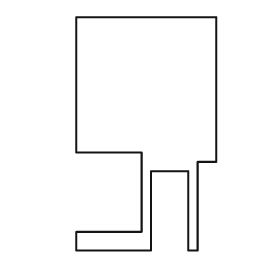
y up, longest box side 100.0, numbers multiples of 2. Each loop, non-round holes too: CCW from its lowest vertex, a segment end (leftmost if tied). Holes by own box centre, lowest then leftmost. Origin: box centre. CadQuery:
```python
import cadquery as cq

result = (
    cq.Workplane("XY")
    .moveTo(-30.0, -50.0)
    .lineTo(2.0, -50.0)
    .lineTo(2.0, -16.0)
    .lineTo(18.0, -16.0)
    .lineTo(18.0, -50.0)
    .lineTo(22.0, -50.0)
    .lineTo(22.0, -12.0)
    .lineTo(30.0, -12.0)
    .lineTo(30.0, 50.0)
    .lineTo(-30.0, 50.0)
    .lineTo(-30.0, -8.0)
    .lineTo(-2.0, -8.0)
    .lineTo(-2.0, -42.0)
    .lineTo(-30.0, -42.0)
    .close()
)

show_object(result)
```